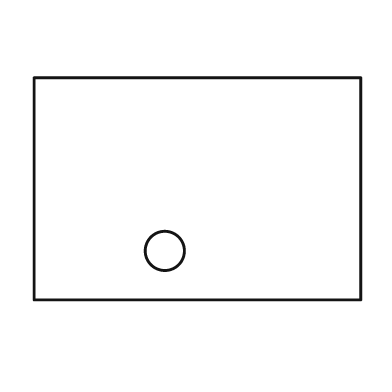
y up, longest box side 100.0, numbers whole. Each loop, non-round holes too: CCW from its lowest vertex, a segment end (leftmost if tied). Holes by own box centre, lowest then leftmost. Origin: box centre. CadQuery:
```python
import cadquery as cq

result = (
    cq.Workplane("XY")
    .moveTo(-50.0, -34.0)
    .lineTo(50.0, -34.0)
    .lineTo(50.0, 34.0)
    .lineTo(-50.0, 34.0)
    .close()
    .moveTo(-10.0, -19.0)
    .circle(6.0)
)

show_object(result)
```